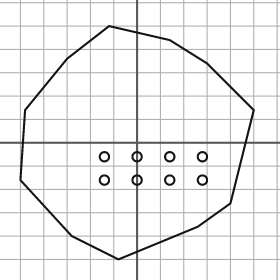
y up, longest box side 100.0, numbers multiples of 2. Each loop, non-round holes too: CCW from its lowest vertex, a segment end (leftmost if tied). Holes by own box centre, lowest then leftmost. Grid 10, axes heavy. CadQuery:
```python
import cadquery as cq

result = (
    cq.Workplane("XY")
    .moveTo(-8.0, -50.0)
    .lineTo(26.0, -36.0)
    .lineTo(40.0, -26.0)
    .lineTo(50.0, 14.0)
    .lineTo(30.0, 34.0)
    .lineTo(14.0, 44.0)
    .lineTo(-12.0, 50.0)
    .lineTo(-30.0, 36.0)
    .lineTo(-48.0, 14.0)
    .lineTo(-50.0, -16.0)
    .lineTo(-28.0, -40.0)
    .close()
    .moveTo(-14.0, -16.0)
    .circle(2.0)
    .moveTo(0.0, -16.0)
    .circle(2.0)
    .moveTo(14.0, -16.0)
    .circle(2.0)
    .moveTo(28.0, -16.0)
    .circle(2.0)
    .moveTo(-14.0, -6.0)
    .circle(2.0)
    .moveTo(0.0, -6.0)
    .circle(2.0)
    .moveTo(14.0, -6.0)
    .circle(2.0)
    .moveTo(28.0, -6.0)
    .circle(2.0)
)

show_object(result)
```